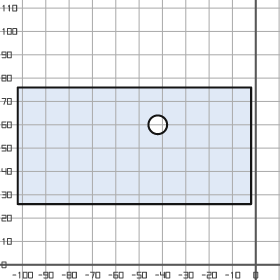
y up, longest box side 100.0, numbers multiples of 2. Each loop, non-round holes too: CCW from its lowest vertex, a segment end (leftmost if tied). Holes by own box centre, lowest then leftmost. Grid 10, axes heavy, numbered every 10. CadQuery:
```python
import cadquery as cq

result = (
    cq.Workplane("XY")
    .moveTo(-102.0, 26.0)
    .lineTo(-2.0, 26.0)
    .lineTo(-2.0, 76.0)
    .lineTo(-102.0, 76.0)
    .close()
    .moveTo(-42.0, 60.0)
    .circle(4.0)
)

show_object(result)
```